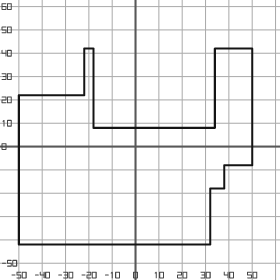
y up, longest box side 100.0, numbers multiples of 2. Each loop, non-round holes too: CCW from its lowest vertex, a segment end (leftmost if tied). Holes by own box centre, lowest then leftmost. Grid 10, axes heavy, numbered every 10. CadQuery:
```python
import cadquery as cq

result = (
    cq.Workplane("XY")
    .moveTo(-50.0, -42.0)
    .lineTo(32.0, -42.0)
    .lineTo(32.0, -18.0)
    .lineTo(38.0, -18.0)
    .lineTo(38.0, -8.0)
    .lineTo(50.0, -8.0)
    .lineTo(50.0, 42.0)
    .lineTo(34.0, 42.0)
    .lineTo(34.0, 8.0)
    .lineTo(-18.0, 8.0)
    .lineTo(-18.0, 42.0)
    .lineTo(-22.0, 42.0)
    .lineTo(-22.0, 22.0)
    .lineTo(-50.0, 22.0)
    .close()
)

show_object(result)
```